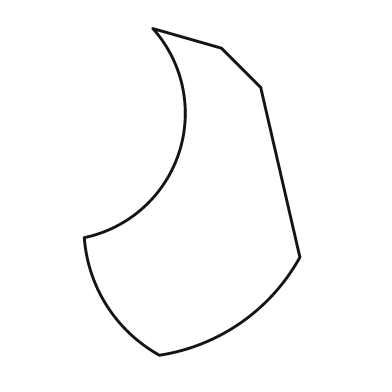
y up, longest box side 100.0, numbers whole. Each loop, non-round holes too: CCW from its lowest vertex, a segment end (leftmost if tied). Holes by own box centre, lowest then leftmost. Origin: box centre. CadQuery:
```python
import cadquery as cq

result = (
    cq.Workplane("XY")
    .moveTo(-10.0, -50.0)
    .threePointArc((15.0, -40.0), (33.0, -20.0))
    .lineTo(21.0, 32.0)
    .lineTo(9.0, 44.0)
    .lineTo(-12.0, 50.0)
    .threePointArc((-4.0, 12.0), (-33.0, -14.0))
    .threePointArc((-26.0, -35.0), (-10.0, -50.0))
    .close()
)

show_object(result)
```